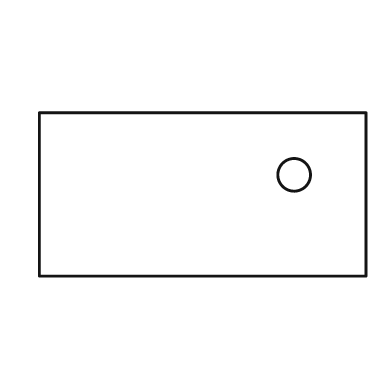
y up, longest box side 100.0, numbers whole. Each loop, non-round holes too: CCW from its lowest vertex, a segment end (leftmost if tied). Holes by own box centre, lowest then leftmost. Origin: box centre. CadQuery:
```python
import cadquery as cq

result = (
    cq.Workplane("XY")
    .moveTo(-50.0, -25.0)
    .lineTo(50.0, -25.0)
    .lineTo(50.0, 25.0)
    .lineTo(-50.0, 25.0)
    .close()
    .moveTo(28.0, 6.0)
    .circle(5.0)
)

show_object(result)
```